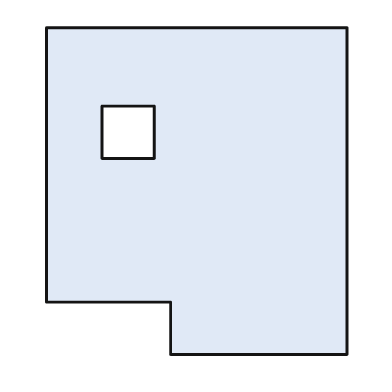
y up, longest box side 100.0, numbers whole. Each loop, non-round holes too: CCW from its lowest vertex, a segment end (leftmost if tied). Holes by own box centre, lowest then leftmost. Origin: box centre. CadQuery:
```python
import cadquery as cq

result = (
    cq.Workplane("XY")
    .moveTo(-8.0, -50.0)
    .lineTo(46.0, -50.0)
    .lineTo(46.0, 50.0)
    .lineTo(-46.0, 50.0)
    .lineTo(-46.0, -34.0)
    .lineTo(-8.0, -34.0)
    .close()
    .moveTo(-29.0, 10.0)
    .lineTo(-13.0, 10.0)
    .lineTo(-13.0, 26.0)
    .lineTo(-29.0, 26.0)
    .close()
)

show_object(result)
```